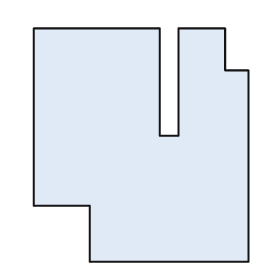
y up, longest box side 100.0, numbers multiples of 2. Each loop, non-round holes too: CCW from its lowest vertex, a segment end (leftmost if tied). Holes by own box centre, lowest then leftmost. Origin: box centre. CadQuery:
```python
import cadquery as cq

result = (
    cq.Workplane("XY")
    .moveTo(-22.0, -50.0)
    .lineTo(46.0, -50.0)
    .lineTo(46.0, 32.0)
    .lineTo(36.0, 32.0)
    .lineTo(36.0, 50.0)
    .lineTo(16.0, 50.0)
    .lineTo(16.0, 4.0)
    .lineTo(8.0, 4.0)
    .lineTo(8.0, 50.0)
    .lineTo(-46.0, 50.0)
    .lineTo(-46.0, -26.0)
    .lineTo(-22.0, -26.0)
    .close()
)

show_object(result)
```